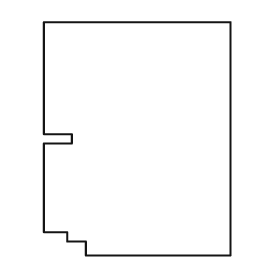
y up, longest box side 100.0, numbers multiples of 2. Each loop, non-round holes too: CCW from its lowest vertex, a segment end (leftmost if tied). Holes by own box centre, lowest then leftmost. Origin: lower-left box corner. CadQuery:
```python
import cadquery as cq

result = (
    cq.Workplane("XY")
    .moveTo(18.0, 0.0)
    .lineTo(80.0, 0.0)
    .lineTo(80.0, 100.0)
    .lineTo(0.0, 100.0)
    .lineTo(0.0, 52.0)
    .lineTo(12.0, 52.0)
    .lineTo(12.0, 48.0)
    .lineTo(0.0, 48.0)
    .lineTo(0.0, 10.0)
    .lineTo(10.0, 10.0)
    .lineTo(10.0, 6.0)
    .lineTo(18.0, 6.0)
    .close()
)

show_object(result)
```